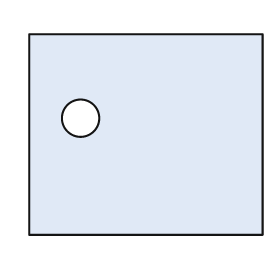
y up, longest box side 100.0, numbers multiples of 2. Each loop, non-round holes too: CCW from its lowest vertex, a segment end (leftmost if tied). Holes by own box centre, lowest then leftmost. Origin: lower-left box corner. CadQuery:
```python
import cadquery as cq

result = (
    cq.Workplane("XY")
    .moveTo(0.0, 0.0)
    .lineTo(100.0, 0.0)
    .lineTo(100.0, 86.0)
    .lineTo(0.0, 86.0)
    .close()
    .moveTo(22.0, 50.0)
    .circle(8.0)
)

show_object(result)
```